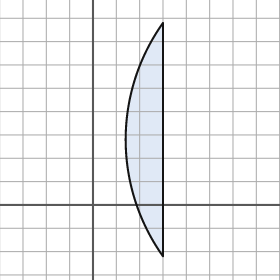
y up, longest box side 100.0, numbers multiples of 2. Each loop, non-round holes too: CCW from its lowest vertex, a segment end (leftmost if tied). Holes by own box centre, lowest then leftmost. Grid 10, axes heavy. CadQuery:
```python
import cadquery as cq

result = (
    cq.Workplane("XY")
    .moveTo(30.0, -22.0)
    .lineTo(30.0, 78.0)
    .threePointArc((14.0, 28.0), (30.0, -22.0))
    .close()
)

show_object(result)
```